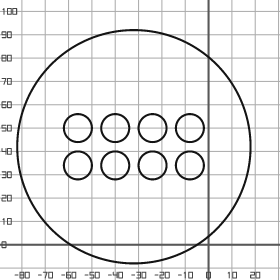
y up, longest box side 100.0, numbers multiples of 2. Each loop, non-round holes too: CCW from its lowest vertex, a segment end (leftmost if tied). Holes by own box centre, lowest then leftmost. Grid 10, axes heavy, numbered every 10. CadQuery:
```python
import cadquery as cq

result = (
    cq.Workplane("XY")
    .moveTo(-32.0, 42.0)
    .circle(50.0)
    .moveTo(-56.0, 34.0)
    .circle(6.0)
    .moveTo(-40.0, 34.0)
    .circle(6.0)
    .moveTo(-24.0, 34.0)
    .circle(6.0)
    .moveTo(-8.0, 34.0)
    .circle(6.0)
    .moveTo(-56.0, 50.0)
    .circle(6.0)
    .moveTo(-40.0, 50.0)
    .circle(6.0)
    .moveTo(-24.0, 50.0)
    .circle(6.0)
    .moveTo(-8.0, 50.0)
    .circle(6.0)
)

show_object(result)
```